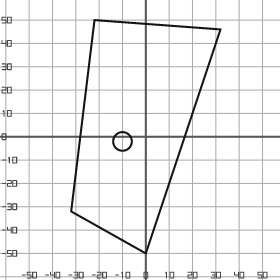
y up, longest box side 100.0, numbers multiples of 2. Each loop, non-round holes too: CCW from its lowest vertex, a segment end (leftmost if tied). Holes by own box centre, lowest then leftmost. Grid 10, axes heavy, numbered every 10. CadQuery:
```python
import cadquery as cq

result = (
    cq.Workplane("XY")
    .moveTo(0.0, -50.0)
    .lineTo(32.0, 46.0)
    .lineTo(-22.0, 50.0)
    .lineTo(-32.0, -32.0)
    .close()
    .moveTo(-10.0, -2.0)
    .circle(4.0)
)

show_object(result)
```